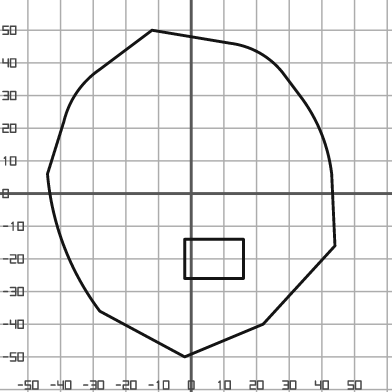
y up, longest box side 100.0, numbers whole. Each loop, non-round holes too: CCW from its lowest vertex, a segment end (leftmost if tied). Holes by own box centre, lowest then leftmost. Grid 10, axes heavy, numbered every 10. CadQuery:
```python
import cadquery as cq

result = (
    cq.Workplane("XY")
    .moveTo(-2.0, -50.0)
    .lineTo(22.0, -40.0)
    .lineTo(44.0, -16.0)
    .lineTo(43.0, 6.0)
    .threePointArc((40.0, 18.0), (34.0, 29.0))
    .lineTo(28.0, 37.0)
    .threePointArc((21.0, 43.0), (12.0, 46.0))
    .lineTo(-12.0, 50.0)
    .lineTo(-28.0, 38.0)
    .threePointArc((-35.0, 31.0), (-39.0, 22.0))
    .lineTo(-44.0, 6.0)
    .threePointArc((-39.0, -16.0), (-28.0, -36.0))
    .close()
    .moveTo(-2.0, -26.0)
    .lineTo(16.0, -26.0)
    .lineTo(16.0, -14.0)
    .lineTo(-2.0, -14.0)
    .close()
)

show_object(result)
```